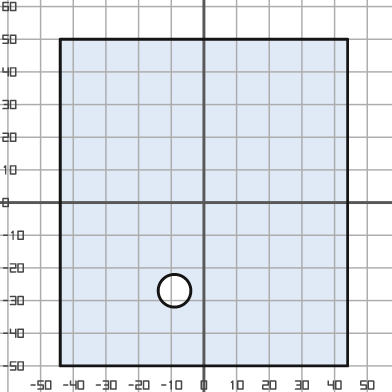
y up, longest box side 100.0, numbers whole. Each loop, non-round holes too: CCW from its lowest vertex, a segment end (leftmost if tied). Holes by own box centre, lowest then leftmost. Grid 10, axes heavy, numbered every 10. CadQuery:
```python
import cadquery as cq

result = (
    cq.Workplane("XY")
    .moveTo(-44.0, -50.0)
    .lineTo(44.0, -50.0)
    .lineTo(44.0, 50.0)
    .lineTo(-44.0, 50.0)
    .close()
    .moveTo(-9.0, -27.0)
    .circle(5.0)
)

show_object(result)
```